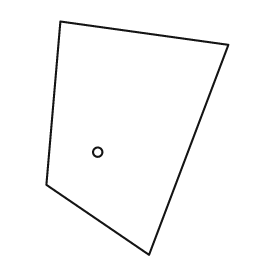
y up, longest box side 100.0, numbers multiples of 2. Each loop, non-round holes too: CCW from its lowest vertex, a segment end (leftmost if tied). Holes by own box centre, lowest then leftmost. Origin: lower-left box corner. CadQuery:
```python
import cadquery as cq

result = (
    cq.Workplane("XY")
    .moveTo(44.0, 0.0)
    .lineTo(78.0, 90.0)
    .lineTo(6.0, 100.0)
    .lineTo(0.0, 30.0)
    .close()
    .moveTo(22.0, 44.0)
    .circle(2.0)
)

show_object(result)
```